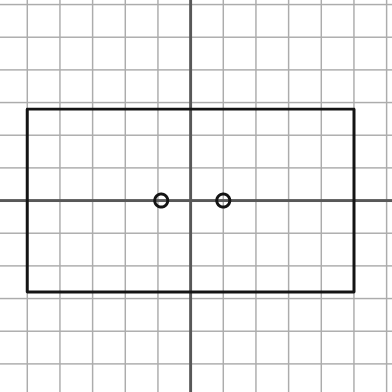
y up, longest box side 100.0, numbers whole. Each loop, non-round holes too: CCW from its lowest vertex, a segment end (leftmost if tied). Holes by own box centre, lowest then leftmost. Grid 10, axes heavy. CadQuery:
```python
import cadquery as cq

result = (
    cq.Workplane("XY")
    .moveTo(-50.0, -28.0)
    .lineTo(50.0, -28.0)
    .lineTo(50.0, 28.0)
    .lineTo(-50.0, 28.0)
    .close()
    .moveTo(-9.0, 0.0)
    .circle(2.0)
    .moveTo(10.0, 0.0)
    .circle(2.0)
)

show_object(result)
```